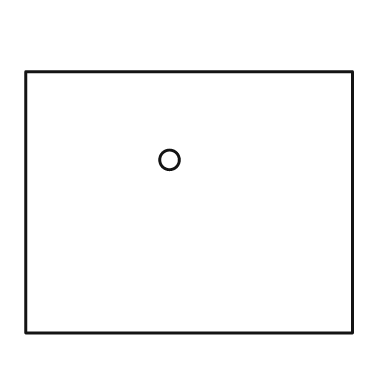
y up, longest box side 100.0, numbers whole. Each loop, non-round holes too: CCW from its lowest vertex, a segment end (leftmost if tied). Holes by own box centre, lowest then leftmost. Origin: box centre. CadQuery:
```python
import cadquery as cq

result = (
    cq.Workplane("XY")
    .moveTo(-50.0, -40.0)
    .lineTo(50.0, -40.0)
    .lineTo(50.0, 40.0)
    .lineTo(-50.0, 40.0)
    .close()
    .moveTo(-6.0, 13.0)
    .circle(3.0)
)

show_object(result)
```